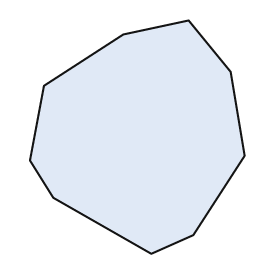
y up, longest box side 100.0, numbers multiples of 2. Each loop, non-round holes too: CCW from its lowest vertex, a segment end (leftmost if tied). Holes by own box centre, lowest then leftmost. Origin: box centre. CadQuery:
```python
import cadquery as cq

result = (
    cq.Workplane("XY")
    .moveTo(6.0, -50.0)
    .lineTo(24.0, -42.0)
    .lineTo(46.0, -8.0)
    .lineTo(40.0, 28.0)
    .lineTo(22.0, 50.0)
    .lineTo(-6.0, 44.0)
    .lineTo(-40.0, 22.0)
    .lineTo(-46.0, -10.0)
    .lineTo(-36.0, -26.0)
    .close()
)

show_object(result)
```